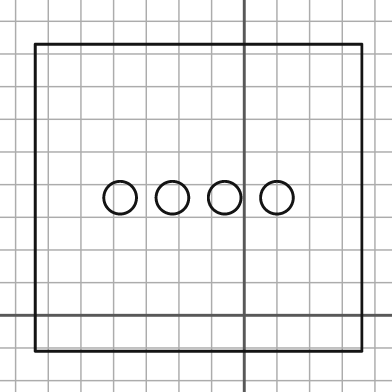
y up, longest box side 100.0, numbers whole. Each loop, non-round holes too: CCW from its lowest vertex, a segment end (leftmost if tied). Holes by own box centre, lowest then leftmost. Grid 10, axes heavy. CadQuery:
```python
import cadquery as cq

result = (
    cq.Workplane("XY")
    .moveTo(-64.0, -11.0)
    .lineTo(36.0, -11.0)
    .lineTo(36.0, 83.0)
    .lineTo(-64.0, 83.0)
    .close()
    .moveTo(-38.0, 36.0)
    .circle(5.0)
    .moveTo(-22.0, 36.0)
    .circle(5.0)
    .moveTo(-6.0, 36.0)
    .circle(5.0)
    .moveTo(10.0, 36.0)
    .circle(5.0)
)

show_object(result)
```